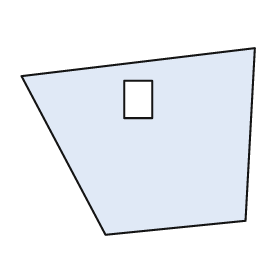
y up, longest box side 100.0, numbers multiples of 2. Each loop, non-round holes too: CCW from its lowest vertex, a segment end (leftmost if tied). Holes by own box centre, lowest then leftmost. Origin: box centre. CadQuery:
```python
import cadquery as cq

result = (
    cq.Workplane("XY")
    .moveTo(-14.0, -40.0)
    .lineTo(46.0, -34.0)
    .lineTo(50.0, 40.0)
    .lineTo(-50.0, 28.0)
    .close()
    .moveTo(-6.0, 10.0)
    .lineTo(6.0, 10.0)
    .lineTo(6.0, 26.0)
    .lineTo(-6.0, 26.0)
    .close()
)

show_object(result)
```